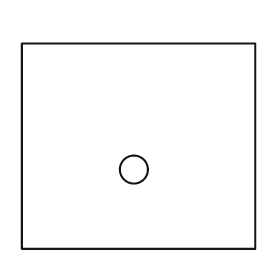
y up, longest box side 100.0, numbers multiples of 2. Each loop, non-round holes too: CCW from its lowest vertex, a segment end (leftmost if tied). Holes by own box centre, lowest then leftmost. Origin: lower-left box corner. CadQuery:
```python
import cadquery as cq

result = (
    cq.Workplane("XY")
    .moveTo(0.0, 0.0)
    .lineTo(100.0, 0.0)
    .lineTo(100.0, 88.0)
    .lineTo(0.0, 88.0)
    .close()
    .moveTo(48.0, 34.0)
    .circle(6.0)
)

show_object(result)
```